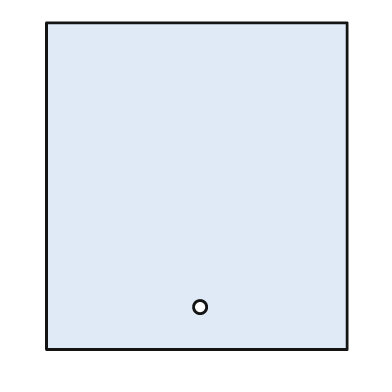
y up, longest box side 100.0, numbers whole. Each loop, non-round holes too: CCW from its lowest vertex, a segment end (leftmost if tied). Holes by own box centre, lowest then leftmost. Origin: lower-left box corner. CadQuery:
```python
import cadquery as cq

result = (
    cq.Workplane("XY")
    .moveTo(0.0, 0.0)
    .lineTo(92.0, 0.0)
    .lineTo(92.0, 100.0)
    .lineTo(0.0, 100.0)
    .close()
    .moveTo(47.0, 13.0)
    .circle(2.0)
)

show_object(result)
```